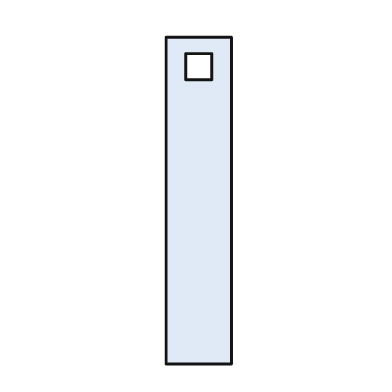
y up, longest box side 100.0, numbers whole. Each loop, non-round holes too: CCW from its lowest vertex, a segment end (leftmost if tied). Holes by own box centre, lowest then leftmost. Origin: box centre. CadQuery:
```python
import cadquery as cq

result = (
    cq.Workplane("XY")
    .moveTo(-10.0, -50.0)
    .lineTo(10.0, -50.0)
    .lineTo(10.0, 50.0)
    .lineTo(-10.0, 50.0)
    .close()
    .moveTo(-4.0, 37.0)
    .lineTo(4.0, 37.0)
    .lineTo(4.0, 45.0)
    .lineTo(-4.0, 45.0)
    .close()
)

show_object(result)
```